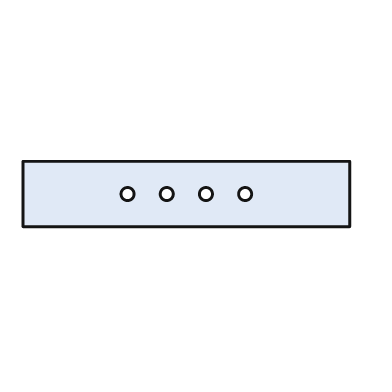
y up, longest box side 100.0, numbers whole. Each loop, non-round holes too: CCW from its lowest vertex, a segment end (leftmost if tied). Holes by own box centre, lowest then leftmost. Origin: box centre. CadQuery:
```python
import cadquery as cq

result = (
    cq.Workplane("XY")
    .moveTo(-50.0, -10.0)
    .lineTo(50.0, -10.0)
    .lineTo(50.0, 10.0)
    .lineTo(-50.0, 10.0)
    .close()
    .moveTo(-18.0, 0.0)
    .circle(2.0)
    .moveTo(-6.0, 0.0)
    .circle(2.0)
    .moveTo(6.0, 0.0)
    .circle(2.0)
    .moveTo(18.0, 0.0)
    .circle(2.0)
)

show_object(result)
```